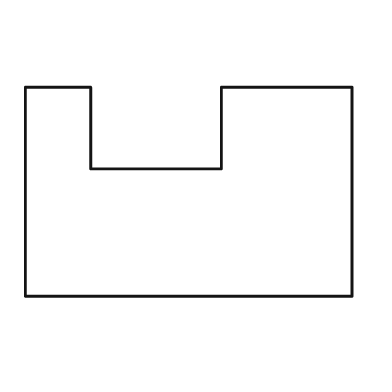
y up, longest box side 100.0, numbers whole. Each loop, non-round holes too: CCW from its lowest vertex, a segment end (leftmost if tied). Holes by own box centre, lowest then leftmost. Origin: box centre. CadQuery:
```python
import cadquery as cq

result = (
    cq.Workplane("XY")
    .moveTo(-50.0, -32.0)
    .lineTo(50.0, -32.0)
    .lineTo(50.0, 32.0)
    .lineTo(10.0, 32.0)
    .lineTo(10.0, 7.0)
    .lineTo(-30.0, 7.0)
    .lineTo(-30.0, 32.0)
    .lineTo(-50.0, 32.0)
    .close()
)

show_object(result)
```